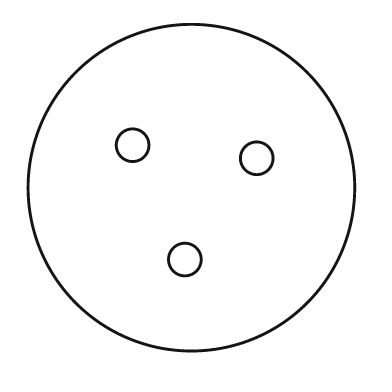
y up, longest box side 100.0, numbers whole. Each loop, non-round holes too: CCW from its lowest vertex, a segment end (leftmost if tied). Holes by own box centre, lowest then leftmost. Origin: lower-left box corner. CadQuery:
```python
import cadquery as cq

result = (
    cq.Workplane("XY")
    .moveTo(50.0, 50.0)
    .circle(50.0)
    .moveTo(48.0, 28.0)
    .circle(5.0)
    .moveTo(70.0, 59.0)
    .circle(5.0)
    .moveTo(32.0, 63.0)
    .circle(5.0)
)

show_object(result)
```